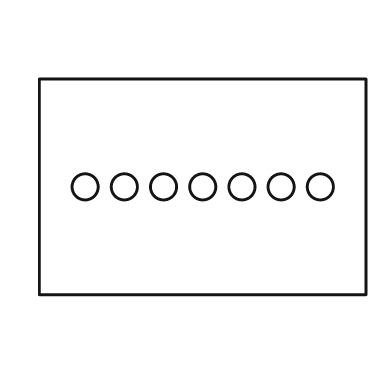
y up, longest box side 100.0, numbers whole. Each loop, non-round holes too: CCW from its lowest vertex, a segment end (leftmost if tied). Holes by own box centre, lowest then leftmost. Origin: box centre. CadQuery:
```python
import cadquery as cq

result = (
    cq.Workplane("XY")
    .moveTo(-50.0, -33.0)
    .lineTo(50.0, -33.0)
    .lineTo(50.0, 33.0)
    .lineTo(-50.0, 33.0)
    .close()
    .moveTo(-36.0, 0.0)
    .circle(4.0)
    .moveTo(-24.0, 0.0)
    .circle(4.0)
    .moveTo(-12.0, 0.0)
    .circle(4.0)
    .moveTo(0.0, 0.0)
    .circle(4.0)
    .moveTo(12.0, 0.0)
    .circle(4.0)
    .moveTo(24.0, 0.0)
    .circle(4.0)
    .moveTo(36.0, 0.0)
    .circle(4.0)
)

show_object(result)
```